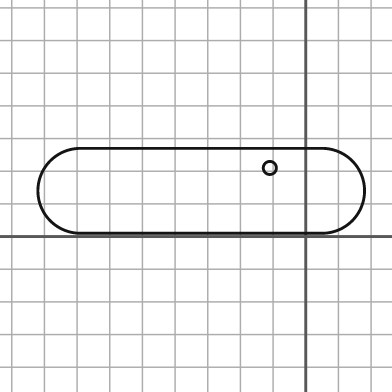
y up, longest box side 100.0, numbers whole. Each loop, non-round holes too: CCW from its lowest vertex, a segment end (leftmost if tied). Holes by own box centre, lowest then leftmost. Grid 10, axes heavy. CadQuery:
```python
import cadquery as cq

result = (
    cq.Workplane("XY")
    .moveTo(-69.0, 1.0)
    .lineTo(5.0, 1.0)
    .threePointArc((18.0, 14.0), (5.0, 27.0))
    .lineTo(-69.0, 27.0)
    .threePointArc((-82.0, 14.0), (-69.0, 1.0))
    .close()
    .moveTo(-11.0, 21.0)
    .circle(2.0)
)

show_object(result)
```